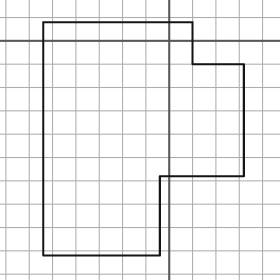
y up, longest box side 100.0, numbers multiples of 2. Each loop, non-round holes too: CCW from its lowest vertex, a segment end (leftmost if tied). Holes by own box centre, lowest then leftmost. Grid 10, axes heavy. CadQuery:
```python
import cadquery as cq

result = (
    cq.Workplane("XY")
    .moveTo(-54.0, -92.0)
    .lineTo(-4.0, -92.0)
    .lineTo(-4.0, -58.0)
    .lineTo(32.0, -58.0)
    .lineTo(32.0, -10.0)
    .lineTo(10.0, -10.0)
    .lineTo(10.0, 8.0)
    .lineTo(-54.0, 8.0)
    .close()
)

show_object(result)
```